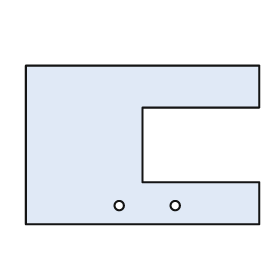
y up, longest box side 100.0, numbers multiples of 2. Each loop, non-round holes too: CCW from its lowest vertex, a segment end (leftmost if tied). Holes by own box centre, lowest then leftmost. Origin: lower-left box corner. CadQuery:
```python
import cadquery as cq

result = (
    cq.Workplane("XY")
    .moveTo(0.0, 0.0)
    .lineTo(100.0, 0.0)
    .lineTo(100.0, 18.0)
    .lineTo(50.0, 18.0)
    .lineTo(50.0, 50.0)
    .lineTo(100.0, 50.0)
    .lineTo(100.0, 68.0)
    .lineTo(0.0, 68.0)
    .close()
    .moveTo(40.0, 8.0)
    .circle(2.0)
    .moveTo(64.0, 8.0)
    .circle(2.0)
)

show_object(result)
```